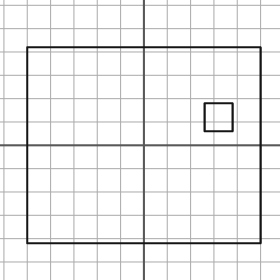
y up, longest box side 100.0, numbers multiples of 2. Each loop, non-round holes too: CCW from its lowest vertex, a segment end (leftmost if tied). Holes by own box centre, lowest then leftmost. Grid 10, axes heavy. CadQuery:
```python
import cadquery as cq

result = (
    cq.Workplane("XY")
    .moveTo(-50.0, -42.0)
    .lineTo(50.0, -42.0)
    .lineTo(50.0, 42.0)
    .lineTo(-50.0, 42.0)
    .close()
    .moveTo(26.0, 6.0)
    .lineTo(38.0, 6.0)
    .lineTo(38.0, 18.0)
    .lineTo(26.0, 18.0)
    .close()
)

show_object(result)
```